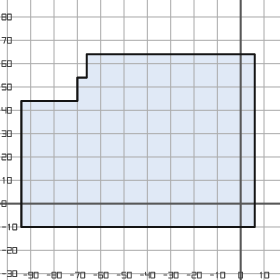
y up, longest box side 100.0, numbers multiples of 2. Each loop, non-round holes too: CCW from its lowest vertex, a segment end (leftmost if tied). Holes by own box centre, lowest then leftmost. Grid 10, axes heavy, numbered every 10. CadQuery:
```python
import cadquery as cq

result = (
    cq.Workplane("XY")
    .moveTo(-94.0, -10.0)
    .lineTo(6.0, -10.0)
    .lineTo(6.0, 64.0)
    .lineTo(-66.0, 64.0)
    .lineTo(-66.0, 54.0)
    .lineTo(-70.0, 54.0)
    .lineTo(-70.0, 44.0)
    .lineTo(-94.0, 44.0)
    .close()
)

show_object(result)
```